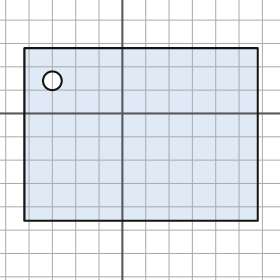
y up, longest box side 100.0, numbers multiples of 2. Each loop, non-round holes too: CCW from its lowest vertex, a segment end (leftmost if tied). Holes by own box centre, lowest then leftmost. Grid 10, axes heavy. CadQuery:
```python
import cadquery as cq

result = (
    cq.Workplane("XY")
    .moveTo(-42.0, -46.0)
    .lineTo(58.0, -46.0)
    .lineTo(58.0, 28.0)
    .lineTo(-42.0, 28.0)
    .close()
    .moveTo(-30.0, 14.0)
    .circle(4.0)
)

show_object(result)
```